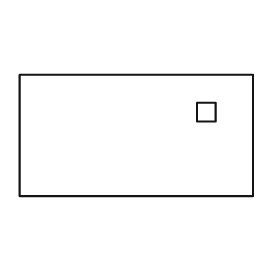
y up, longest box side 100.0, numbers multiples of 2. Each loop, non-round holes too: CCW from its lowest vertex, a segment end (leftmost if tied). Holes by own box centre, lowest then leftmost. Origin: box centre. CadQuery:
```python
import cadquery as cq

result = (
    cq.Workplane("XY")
    .moveTo(-50.0, -26.0)
    .lineTo(50.0, -26.0)
    .lineTo(50.0, 26.0)
    .lineTo(-50.0, 26.0)
    .close()
    .moveTo(26.0, 6.0)
    .lineTo(34.0, 6.0)
    .lineTo(34.0, 14.0)
    .lineTo(26.0, 14.0)
    .close()
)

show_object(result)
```